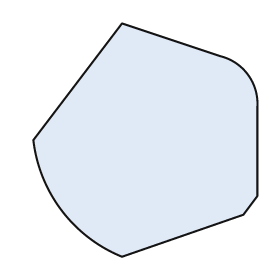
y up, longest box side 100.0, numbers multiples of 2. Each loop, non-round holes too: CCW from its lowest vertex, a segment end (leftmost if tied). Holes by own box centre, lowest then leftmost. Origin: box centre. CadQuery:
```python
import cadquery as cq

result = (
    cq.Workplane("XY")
    .moveTo(-10.0, -50.0)
    .lineTo(42.0, -32.0)
    .lineTo(48.0, -24.0)
    .lineTo(48.0, 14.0)
    .threePointArc((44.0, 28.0), (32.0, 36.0))
    .lineTo(-10.0, 50.0)
    .lineTo(-48.0, 0.0)
    .threePointArc((-36.0, -30.0), (-10.0, -50.0))
    .close()
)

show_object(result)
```